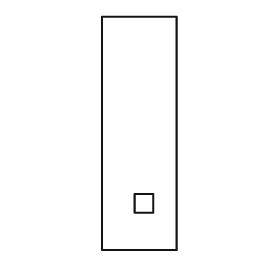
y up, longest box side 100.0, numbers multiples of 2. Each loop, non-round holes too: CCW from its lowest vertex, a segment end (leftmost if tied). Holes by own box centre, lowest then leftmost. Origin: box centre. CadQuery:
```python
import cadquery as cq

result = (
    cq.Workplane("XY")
    .moveTo(-16.0, -50.0)
    .lineTo(16.0, -50.0)
    .lineTo(16.0, 50.0)
    .lineTo(-16.0, 50.0)
    .close()
    .moveTo(-2.0, -34.0)
    .lineTo(6.0, -34.0)
    .lineTo(6.0, -26.0)
    .lineTo(-2.0, -26.0)
    .close()
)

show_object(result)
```